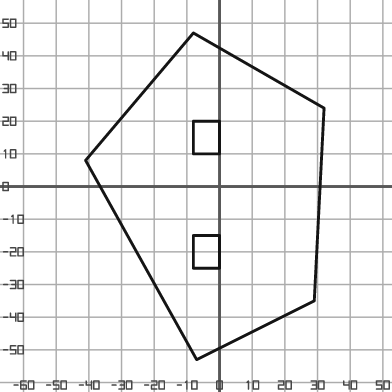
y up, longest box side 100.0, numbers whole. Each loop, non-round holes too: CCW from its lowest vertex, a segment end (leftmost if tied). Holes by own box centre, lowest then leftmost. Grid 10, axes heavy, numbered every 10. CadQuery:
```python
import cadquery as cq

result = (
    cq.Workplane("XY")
    .moveTo(-7.0, -53.0)
    .lineTo(29.0, -35.0)
    .lineTo(32.0, 24.0)
    .lineTo(-8.0, 47.0)
    .lineTo(-41.0, 8.0)
    .close()
    .moveTo(-8.0, -25.0)
    .lineTo(0.0, -25.0)
    .lineTo(0.0, -15.0)
    .lineTo(-8.0, -15.0)
    .close()
    .moveTo(-8.0, 10.0)
    .lineTo(0.0, 10.0)
    .lineTo(0.0, 20.0)
    .lineTo(-8.0, 20.0)
    .close()
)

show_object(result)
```